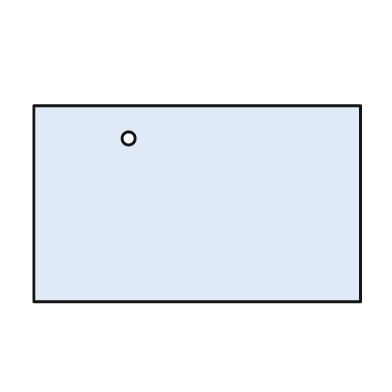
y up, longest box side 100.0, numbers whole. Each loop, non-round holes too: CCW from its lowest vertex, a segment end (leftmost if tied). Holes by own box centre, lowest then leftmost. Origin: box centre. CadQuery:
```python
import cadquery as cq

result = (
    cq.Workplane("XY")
    .moveTo(-50.0, -30.0)
    .lineTo(50.0, -30.0)
    .lineTo(50.0, 30.0)
    .lineTo(-50.0, 30.0)
    .close()
    .moveTo(-21.0, 20.0)
    .circle(2.0)
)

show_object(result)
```